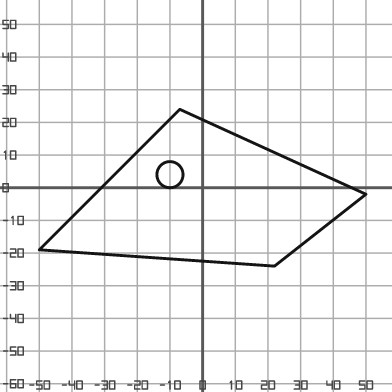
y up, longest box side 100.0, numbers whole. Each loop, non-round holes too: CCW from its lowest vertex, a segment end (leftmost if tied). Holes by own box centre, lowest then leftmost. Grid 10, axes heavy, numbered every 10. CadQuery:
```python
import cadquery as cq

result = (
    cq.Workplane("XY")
    .moveTo(22.0, -24.0)
    .lineTo(50.0, -2.0)
    .lineTo(-7.0, 24.0)
    .lineTo(-50.0, -19.0)
    .close()
    .moveTo(-10.0, 4.0)
    .circle(4.0)
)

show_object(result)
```